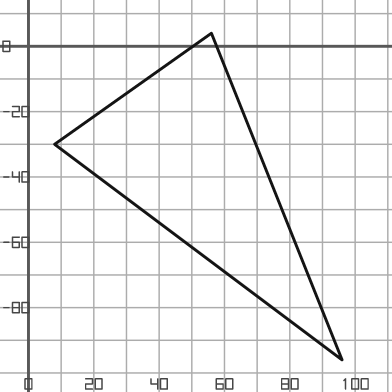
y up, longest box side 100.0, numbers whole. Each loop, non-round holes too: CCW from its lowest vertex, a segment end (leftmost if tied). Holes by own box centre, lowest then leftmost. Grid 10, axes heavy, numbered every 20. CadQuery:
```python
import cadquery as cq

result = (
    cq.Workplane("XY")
    .moveTo(96.0, -96.0)
    .lineTo(56.0, 4.0)
    .lineTo(8.0, -30.0)
    .close()
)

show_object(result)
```